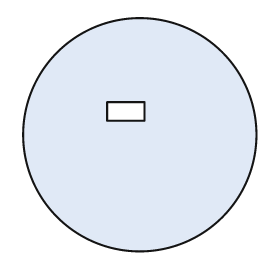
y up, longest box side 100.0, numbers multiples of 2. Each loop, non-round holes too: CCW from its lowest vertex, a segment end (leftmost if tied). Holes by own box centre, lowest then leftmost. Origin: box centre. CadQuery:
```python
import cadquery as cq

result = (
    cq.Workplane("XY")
    .moveTo(0.0, 0.0)
    .circle(50.0)
    .moveTo(-14.0, 6.0)
    .lineTo(2.0, 6.0)
    .lineTo(2.0, 14.0)
    .lineTo(-14.0, 14.0)
    .close()
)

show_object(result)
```